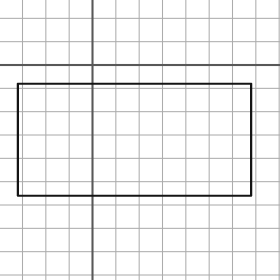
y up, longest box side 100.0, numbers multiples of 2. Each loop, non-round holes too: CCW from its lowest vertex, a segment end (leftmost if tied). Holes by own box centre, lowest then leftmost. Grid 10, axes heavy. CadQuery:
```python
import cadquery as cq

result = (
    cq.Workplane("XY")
    .moveTo(-32.0, -56.0)
    .lineTo(68.0, -56.0)
    .lineTo(68.0, -8.0)
    .lineTo(-32.0, -8.0)
    .close()
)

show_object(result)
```